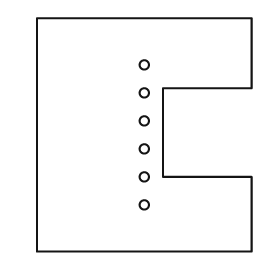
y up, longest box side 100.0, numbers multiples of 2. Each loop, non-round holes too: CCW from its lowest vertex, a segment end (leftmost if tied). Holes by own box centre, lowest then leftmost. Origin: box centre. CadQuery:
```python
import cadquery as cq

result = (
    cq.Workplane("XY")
    .moveTo(-46.0, -50.0)
    .lineTo(46.0, -50.0)
    .lineTo(46.0, -18.0)
    .lineTo(8.0, -18.0)
    .lineTo(8.0, 20.0)
    .lineTo(46.0, 20.0)
    .lineTo(46.0, 50.0)
    .lineTo(-46.0, 50.0)
    .close()
    .moveTo(0.0, -30.0)
    .circle(2.0)
    .moveTo(0.0, -18.0)
    .circle(2.0)
    .moveTo(0.0, -6.0)
    .circle(2.0)
    .moveTo(0.0, 6.0)
    .circle(2.0)
    .moveTo(0.0, 18.0)
    .circle(2.0)
    .moveTo(0.0, 30.0)
    .circle(2.0)
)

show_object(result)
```